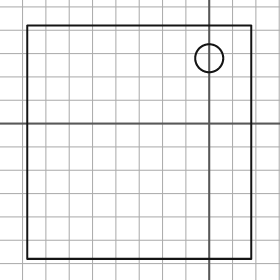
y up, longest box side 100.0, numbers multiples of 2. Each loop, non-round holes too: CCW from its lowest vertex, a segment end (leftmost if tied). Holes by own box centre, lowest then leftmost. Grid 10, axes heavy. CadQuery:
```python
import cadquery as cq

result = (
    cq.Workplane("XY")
    .moveTo(-78.0, -58.0)
    .lineTo(18.0, -58.0)
    .lineTo(18.0, 42.0)
    .lineTo(-78.0, 42.0)
    .close()
    .moveTo(0.0, 28.0)
    .circle(6.0)
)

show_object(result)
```